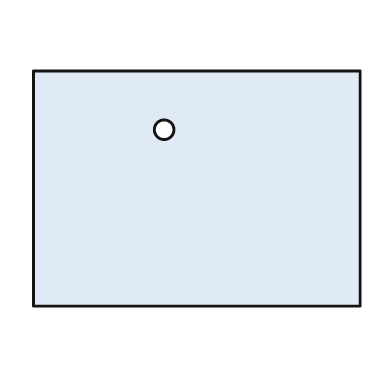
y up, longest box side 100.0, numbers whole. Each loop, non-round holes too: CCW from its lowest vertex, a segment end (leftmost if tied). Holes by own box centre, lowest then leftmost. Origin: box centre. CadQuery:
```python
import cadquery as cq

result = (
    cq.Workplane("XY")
    .moveTo(-50.0, -36.0)
    .lineTo(50.0, -36.0)
    .lineTo(50.0, 36.0)
    .lineTo(-50.0, 36.0)
    .close()
    .moveTo(-10.0, 18.0)
    .circle(3.0)
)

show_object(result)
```